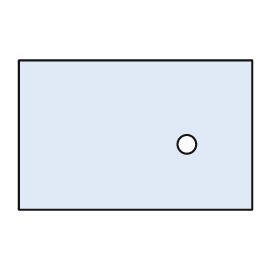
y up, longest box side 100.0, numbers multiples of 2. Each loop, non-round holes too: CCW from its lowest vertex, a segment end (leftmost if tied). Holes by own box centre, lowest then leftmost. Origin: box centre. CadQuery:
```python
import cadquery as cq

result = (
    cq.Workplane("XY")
    .moveTo(-50.0, -32.0)
    .lineTo(50.0, -32.0)
    .lineTo(50.0, 32.0)
    .lineTo(-50.0, 32.0)
    .close()
    .moveTo(22.0, -4.0)
    .circle(4.0)
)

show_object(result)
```